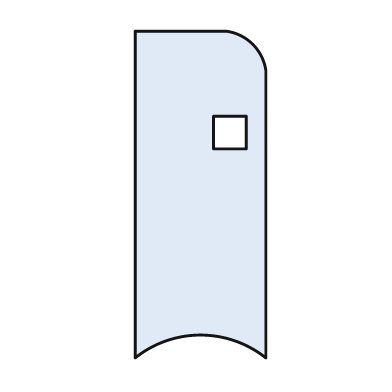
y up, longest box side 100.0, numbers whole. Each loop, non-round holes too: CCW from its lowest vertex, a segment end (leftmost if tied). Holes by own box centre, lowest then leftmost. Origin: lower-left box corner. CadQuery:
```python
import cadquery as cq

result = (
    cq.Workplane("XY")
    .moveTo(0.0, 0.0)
    .threePointArc((20.0, 7.0), (40.0, 0.0))
    .lineTo(40.0, 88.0)
    .threePointArc((36.0, 96.0), (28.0, 100.0))
    .lineTo(0.0, 100.0)
    .close()
    .moveTo(24.0, 64.0)
    .lineTo(34.0, 64.0)
    .lineTo(34.0, 74.0)
    .lineTo(24.0, 74.0)
    .close()
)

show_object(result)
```